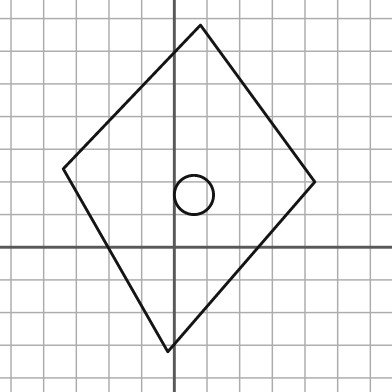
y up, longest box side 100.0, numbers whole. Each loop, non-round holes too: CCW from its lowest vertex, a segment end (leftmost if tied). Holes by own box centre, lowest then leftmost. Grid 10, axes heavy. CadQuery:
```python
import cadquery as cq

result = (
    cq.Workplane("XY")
    .moveTo(-2.0, -32.0)
    .lineTo(43.0, 20.0)
    .lineTo(8.0, 68.0)
    .lineTo(-34.0, 24.0)
    .close()
    .moveTo(6.0, 16.0)
    .circle(6.0)
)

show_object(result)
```